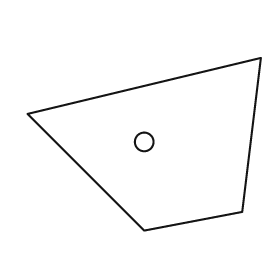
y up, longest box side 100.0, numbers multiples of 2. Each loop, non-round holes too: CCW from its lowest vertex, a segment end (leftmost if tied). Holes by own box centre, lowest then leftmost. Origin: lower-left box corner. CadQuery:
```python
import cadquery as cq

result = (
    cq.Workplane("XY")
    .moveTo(50.0, 0.0)
    .lineTo(92.0, 8.0)
    .lineTo(100.0, 74.0)
    .lineTo(0.0, 50.0)
    .close()
    .moveTo(50.0, 38.0)
    .circle(4.0)
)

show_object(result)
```